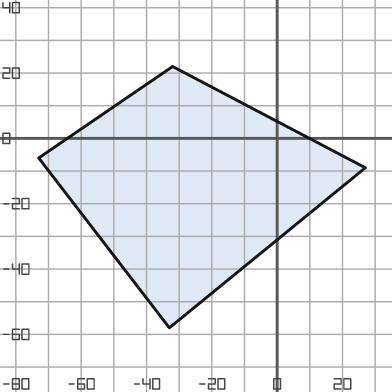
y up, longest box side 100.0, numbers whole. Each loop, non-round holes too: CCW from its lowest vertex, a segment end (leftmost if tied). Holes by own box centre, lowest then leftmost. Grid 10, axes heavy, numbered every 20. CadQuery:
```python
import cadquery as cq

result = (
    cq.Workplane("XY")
    .moveTo(-33.0, -58.0)
    .lineTo(27.0, -9.0)
    .lineTo(-32.0, 22.0)
    .lineTo(-73.0, -6.0)
    .close()
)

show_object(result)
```